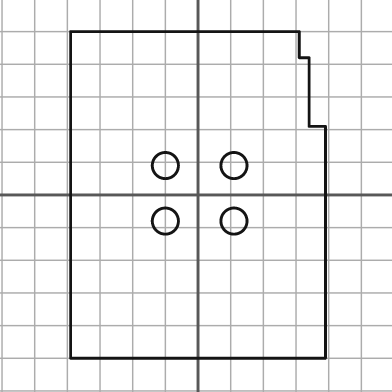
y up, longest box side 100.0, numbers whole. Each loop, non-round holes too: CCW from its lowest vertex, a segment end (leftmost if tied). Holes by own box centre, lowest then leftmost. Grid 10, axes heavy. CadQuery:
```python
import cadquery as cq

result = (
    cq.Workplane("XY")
    .moveTo(-39.0, -50.0)
    .lineTo(39.0, -50.0)
    .lineTo(39.0, 21.0)
    .lineTo(34.0, 21.0)
    .lineTo(34.0, 42.0)
    .lineTo(31.0, 42.0)
    .lineTo(31.0, 50.0)
    .lineTo(-39.0, 50.0)
    .close()
    .moveTo(-10.0, -8.0)
    .circle(4.0)
    .moveTo(11.0, -8.0)
    .circle(4.0)
    .moveTo(-10.0, 9.0)
    .circle(4.0)
    .moveTo(11.0, 9.0)
    .circle(4.0)
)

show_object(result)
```